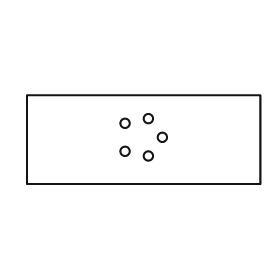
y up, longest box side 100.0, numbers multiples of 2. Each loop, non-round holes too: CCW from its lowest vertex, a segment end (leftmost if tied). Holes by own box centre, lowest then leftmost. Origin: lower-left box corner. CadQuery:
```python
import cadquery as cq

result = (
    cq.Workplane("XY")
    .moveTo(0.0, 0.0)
    .lineTo(100.0, 0.0)
    .lineTo(100.0, 38.0)
    .lineTo(0.0, 38.0)
    .close()
    .moveTo(52.0, 12.0)
    .circle(2.0)
    .moveTo(42.0, 14.0)
    .circle(2.0)
    .moveTo(58.0, 20.0)
    .circle(2.0)
    .moveTo(42.0, 26.0)
    .circle(2.0)
    .moveTo(52.0, 28.0)
    .circle(2.0)
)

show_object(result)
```